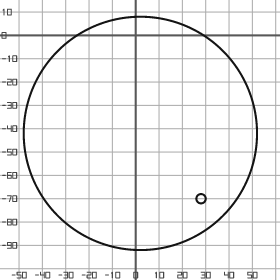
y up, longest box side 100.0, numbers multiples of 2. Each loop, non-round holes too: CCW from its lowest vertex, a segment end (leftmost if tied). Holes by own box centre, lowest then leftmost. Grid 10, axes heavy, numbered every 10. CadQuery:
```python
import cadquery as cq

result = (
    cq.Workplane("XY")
    .moveTo(2.0, -42.0)
    .circle(50.0)
    .moveTo(28.0, -70.0)
    .circle(2.0)
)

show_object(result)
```